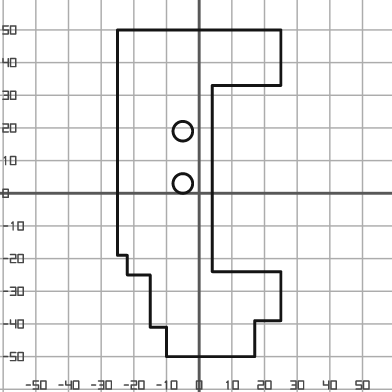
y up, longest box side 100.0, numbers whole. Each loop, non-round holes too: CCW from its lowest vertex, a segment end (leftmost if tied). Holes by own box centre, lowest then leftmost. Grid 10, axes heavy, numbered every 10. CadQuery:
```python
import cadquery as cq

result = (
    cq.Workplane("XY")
    .moveTo(-10.0, -50.0)
    .lineTo(17.0, -50.0)
    .lineTo(17.0, -39.0)
    .lineTo(25.0, -39.0)
    .lineTo(25.0, -24.0)
    .lineTo(4.0, -24.0)
    .lineTo(4.0, 33.0)
    .lineTo(25.0, 33.0)
    .lineTo(25.0, 50.0)
    .lineTo(-25.0, 50.0)
    .lineTo(-25.0, -19.0)
    .lineTo(-22.0, -19.0)
    .lineTo(-22.0, -25.0)
    .lineTo(-15.0, -25.0)
    .lineTo(-15.0, -41.0)
    .lineTo(-10.0, -41.0)
    .close()
    .moveTo(-5.0, 3.0)
    .circle(3.0)
    .moveTo(-5.0, 19.0)
    .circle(3.0)
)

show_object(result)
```